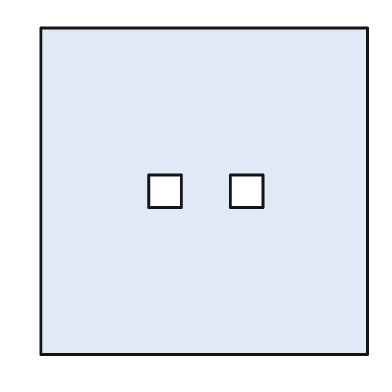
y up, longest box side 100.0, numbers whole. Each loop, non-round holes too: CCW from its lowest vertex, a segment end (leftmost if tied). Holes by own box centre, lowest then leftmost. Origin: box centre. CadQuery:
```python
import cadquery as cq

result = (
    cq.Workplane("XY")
    .moveTo(-50.0, -50.0)
    .lineTo(50.0, -50.0)
    .lineTo(50.0, 50.0)
    .lineTo(-50.0, 50.0)
    .close()
    .moveTo(-17.0, -5.0)
    .lineTo(-7.0, -5.0)
    .lineTo(-7.0, 5.0)
    .lineTo(-17.0, 5.0)
    .close()
    .moveTo(8.0, -5.0)
    .lineTo(18.0, -5.0)
    .lineTo(18.0, 5.0)
    .lineTo(8.0, 5.0)
    .close()
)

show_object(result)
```